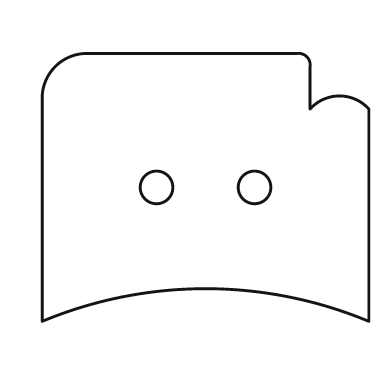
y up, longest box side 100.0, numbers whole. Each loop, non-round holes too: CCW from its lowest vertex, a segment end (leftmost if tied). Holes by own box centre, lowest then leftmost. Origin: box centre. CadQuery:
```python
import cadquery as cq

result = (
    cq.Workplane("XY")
    .moveTo(-50.0, -41.0)
    .threePointArc((0.0, -31.0), (50.0, -41.0))
    .lineTo(50.0, 24.0)
    .threePointArc((41.0, 28.0), (32.0, 24.0))
    .lineTo(32.0, 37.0)
    .threePointArc((31.0, 40.0), (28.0, 41.0))
    .lineTo(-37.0, 41.0)
    .threePointArc((-46.0, 37.0), (-50.0, 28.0))
    .close()
    .moveTo(-15.0, 0.0)
    .circle(5.0)
    .moveTo(15.0, 0.0)
    .circle(5.0)
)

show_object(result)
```